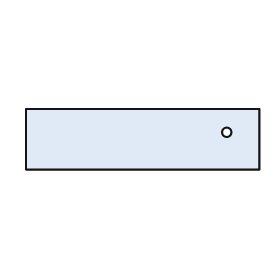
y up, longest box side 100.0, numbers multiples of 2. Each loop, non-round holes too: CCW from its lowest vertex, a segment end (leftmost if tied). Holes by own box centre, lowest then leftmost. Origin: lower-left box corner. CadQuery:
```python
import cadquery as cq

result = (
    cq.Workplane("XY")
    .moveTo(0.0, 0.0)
    .lineTo(100.0, 0.0)
    .lineTo(100.0, 26.0)
    .lineTo(0.0, 26.0)
    .close()
    .moveTo(86.0, 16.0)
    .circle(2.0)
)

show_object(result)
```